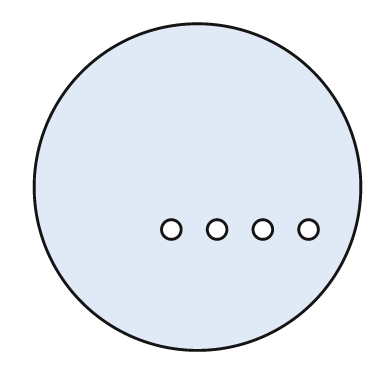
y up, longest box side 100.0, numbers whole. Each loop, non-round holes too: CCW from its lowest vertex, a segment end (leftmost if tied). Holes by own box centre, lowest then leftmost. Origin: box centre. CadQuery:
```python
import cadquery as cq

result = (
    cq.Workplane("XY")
    .moveTo(0.0, 0.0)
    .circle(50.0)
    .moveTo(-8.0, -13.0)
    .circle(3.0)
    .moveTo(6.0, -13.0)
    .circle(3.0)
    .moveTo(20.0, -13.0)
    .circle(3.0)
    .moveTo(34.0, -13.0)
    .circle(3.0)
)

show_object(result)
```